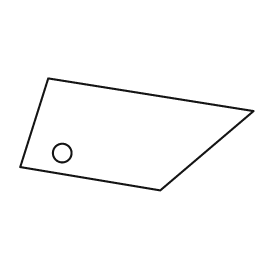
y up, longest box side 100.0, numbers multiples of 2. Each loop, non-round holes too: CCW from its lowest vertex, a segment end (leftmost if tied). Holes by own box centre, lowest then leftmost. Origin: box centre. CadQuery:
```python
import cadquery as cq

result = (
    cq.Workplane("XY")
    .moveTo(10.0, -24.0)
    .lineTo(50.0, 10.0)
    .lineTo(-38.0, 24.0)
    .lineTo(-50.0, -14.0)
    .close()
    .moveTo(-32.0, -8.0)
    .circle(4.0)
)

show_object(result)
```